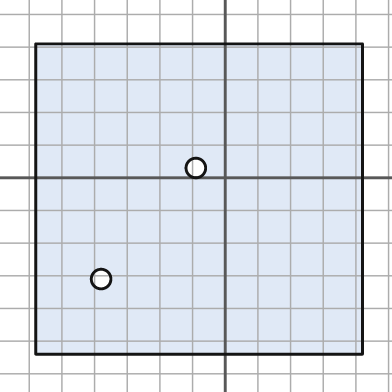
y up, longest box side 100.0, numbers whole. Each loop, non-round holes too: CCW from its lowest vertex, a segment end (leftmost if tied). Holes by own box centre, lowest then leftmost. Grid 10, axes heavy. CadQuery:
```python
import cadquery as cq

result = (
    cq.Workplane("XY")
    .moveTo(-58.0, -54.0)
    .lineTo(42.0, -54.0)
    .lineTo(42.0, 41.0)
    .lineTo(-58.0, 41.0)
    .close()
    .moveTo(-38.0, -31.0)
    .circle(3.0)
    .moveTo(-9.0, 3.0)
    .circle(3.0)
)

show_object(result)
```